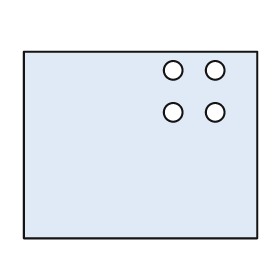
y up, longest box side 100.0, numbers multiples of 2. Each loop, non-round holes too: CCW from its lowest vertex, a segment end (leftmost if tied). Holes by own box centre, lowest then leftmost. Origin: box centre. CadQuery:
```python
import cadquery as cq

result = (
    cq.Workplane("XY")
    .moveTo(-50.0, -40.0)
    .lineTo(50.0, -40.0)
    .lineTo(50.0, 40.0)
    .lineTo(-50.0, 40.0)
    .close()
    .moveTo(14.0, 14.0)
    .circle(4.0)
    .moveTo(32.0, 14.0)
    .circle(4.0)
    .moveTo(14.0, 32.0)
    .circle(4.0)
    .moveTo(32.0, 32.0)
    .circle(4.0)
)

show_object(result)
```